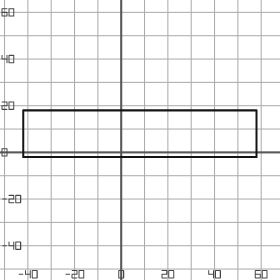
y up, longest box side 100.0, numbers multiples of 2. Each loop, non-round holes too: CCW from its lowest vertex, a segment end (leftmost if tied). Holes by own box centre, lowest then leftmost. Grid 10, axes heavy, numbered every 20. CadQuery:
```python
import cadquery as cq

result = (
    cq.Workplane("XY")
    .moveTo(-42.0, -2.0)
    .lineTo(58.0, -2.0)
    .lineTo(58.0, 18.0)
    .lineTo(-42.0, 18.0)
    .close()
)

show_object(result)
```